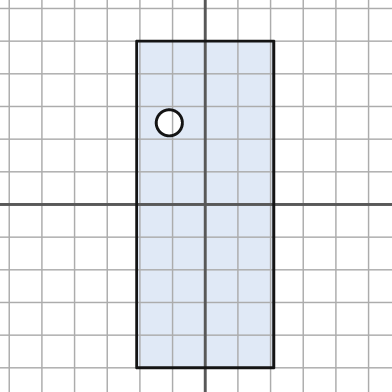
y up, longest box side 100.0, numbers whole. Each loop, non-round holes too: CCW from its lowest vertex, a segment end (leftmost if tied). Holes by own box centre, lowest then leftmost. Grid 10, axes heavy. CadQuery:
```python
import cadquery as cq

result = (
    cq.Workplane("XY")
    .moveTo(-21.0, -50.0)
    .lineTo(21.0, -50.0)
    .lineTo(21.0, 50.0)
    .lineTo(-21.0, 50.0)
    .close()
    .moveTo(-11.0, 25.0)
    .circle(4.0)
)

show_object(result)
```